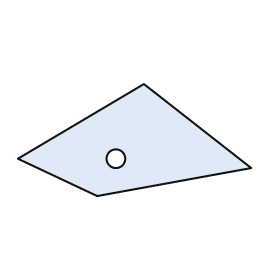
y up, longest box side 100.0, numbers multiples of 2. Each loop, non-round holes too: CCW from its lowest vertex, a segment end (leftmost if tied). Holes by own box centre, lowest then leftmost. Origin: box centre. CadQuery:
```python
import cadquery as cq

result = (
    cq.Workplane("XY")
    .moveTo(-16.0, -24.0)
    .lineTo(50.0, -12.0)
    .lineTo(4.0, 24.0)
    .lineTo(-50.0, -8.0)
    .close()
    .moveTo(-8.0, -8.0)
    .circle(4.0)
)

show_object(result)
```